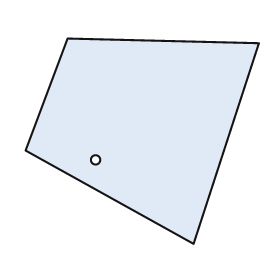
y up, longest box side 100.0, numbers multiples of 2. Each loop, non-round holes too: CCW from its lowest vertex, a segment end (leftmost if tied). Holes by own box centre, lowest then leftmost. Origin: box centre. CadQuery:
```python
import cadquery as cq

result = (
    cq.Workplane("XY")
    .moveTo(22.0, -44.0)
    .lineTo(50.0, 42.0)
    .lineTo(-32.0, 44.0)
    .lineTo(-50.0, -4.0)
    .close()
    .moveTo(-20.0, -8.0)
    .circle(2.0)
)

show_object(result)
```